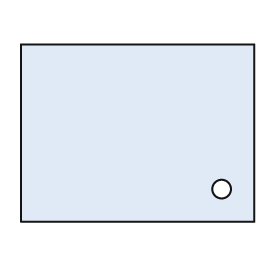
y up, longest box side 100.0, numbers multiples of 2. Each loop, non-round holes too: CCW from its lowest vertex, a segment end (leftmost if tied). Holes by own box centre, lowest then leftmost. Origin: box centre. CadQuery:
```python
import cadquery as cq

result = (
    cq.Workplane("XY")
    .moveTo(-50.0, -38.0)
    .lineTo(50.0, -38.0)
    .lineTo(50.0, 38.0)
    .lineTo(-50.0, 38.0)
    .close()
    .moveTo(36.0, -24.0)
    .circle(4.0)
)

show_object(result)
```